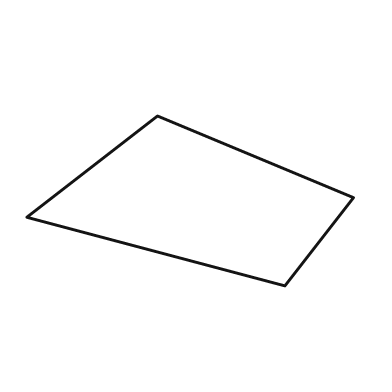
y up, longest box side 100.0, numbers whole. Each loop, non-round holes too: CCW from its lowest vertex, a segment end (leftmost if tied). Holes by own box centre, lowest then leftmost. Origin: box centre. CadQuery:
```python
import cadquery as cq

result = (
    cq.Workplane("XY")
    .moveTo(29.0, -26.0)
    .lineTo(50.0, 1.0)
    .lineTo(-10.0, 26.0)
    .lineTo(-50.0, -5.0)
    .close()
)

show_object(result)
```